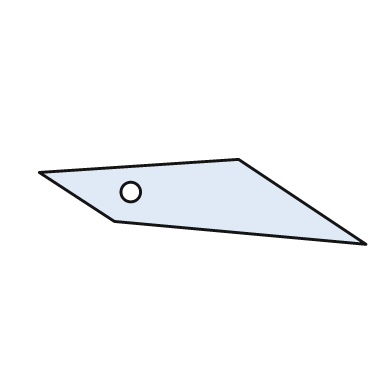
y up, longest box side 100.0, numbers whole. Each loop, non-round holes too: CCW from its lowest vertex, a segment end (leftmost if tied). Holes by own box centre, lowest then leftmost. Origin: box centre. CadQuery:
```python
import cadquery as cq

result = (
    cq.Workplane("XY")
    .moveTo(50.0, -13.0)
    .lineTo(11.0, 13.0)
    .lineTo(-50.0, 9.0)
    .lineTo(-27.0, -6.0)
    .close()
    .moveTo(-22.0, 3.0)
    .circle(3.0)
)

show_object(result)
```